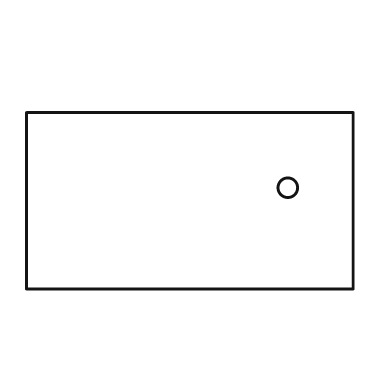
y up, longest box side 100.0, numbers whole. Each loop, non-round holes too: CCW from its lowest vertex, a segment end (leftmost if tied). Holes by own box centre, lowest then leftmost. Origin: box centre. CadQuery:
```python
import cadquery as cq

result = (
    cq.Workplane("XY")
    .moveTo(-50.0, -27.0)
    .lineTo(50.0, -27.0)
    .lineTo(50.0, 27.0)
    .lineTo(-50.0, 27.0)
    .close()
    .moveTo(30.0, 4.0)
    .circle(3.0)
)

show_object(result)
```